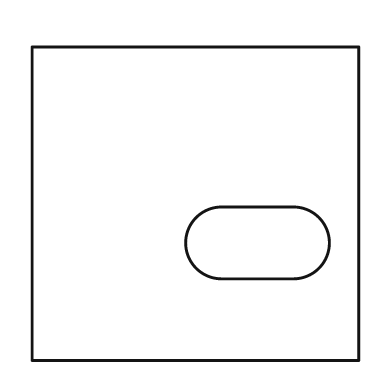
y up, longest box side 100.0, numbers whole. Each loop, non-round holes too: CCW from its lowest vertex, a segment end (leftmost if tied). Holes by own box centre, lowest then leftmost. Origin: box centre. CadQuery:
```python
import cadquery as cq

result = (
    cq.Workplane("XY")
    .moveTo(-50.0, -48.0)
    .lineTo(50.0, -48.0)
    .lineTo(50.0, 48.0)
    .lineTo(-50.0, 48.0)
    .close()
    .moveTo(8.0, -23.0)
    .lineTo(30.0, -23.0)
    .threePointArc((41.0, -12.0), (30.0, -1.0))
    .lineTo(8.0, -1.0)
    .threePointArc((-3.0, -12.0), (8.0, -23.0))
    .close()
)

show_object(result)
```